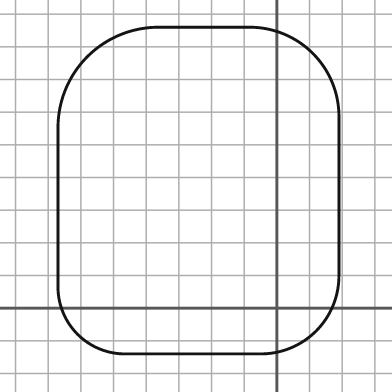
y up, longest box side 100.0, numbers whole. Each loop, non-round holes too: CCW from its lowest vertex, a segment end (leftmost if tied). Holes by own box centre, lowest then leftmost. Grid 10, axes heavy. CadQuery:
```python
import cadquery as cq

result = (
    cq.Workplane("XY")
    .moveTo(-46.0, -14.0)
    .lineTo(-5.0, -14.0)
    .threePointArc((12.0, -7.0), (19.0, 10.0))
    .lineTo(19.0, 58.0)
    .threePointArc((11.0, 78.0), (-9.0, 86.0))
    .lineTo(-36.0, 86.0)
    .threePointArc((-58.0, 77.0), (-67.0, 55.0))
    .lineTo(-67.0, 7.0)
    .threePointArc((-61.0, -8.0), (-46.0, -14.0))
    .close()
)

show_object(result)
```